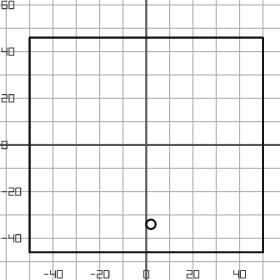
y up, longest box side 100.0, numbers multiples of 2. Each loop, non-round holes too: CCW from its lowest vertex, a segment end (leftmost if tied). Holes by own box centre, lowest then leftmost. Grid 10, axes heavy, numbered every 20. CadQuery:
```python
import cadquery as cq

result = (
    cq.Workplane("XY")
    .moveTo(-50.0, -46.0)
    .lineTo(50.0, -46.0)
    .lineTo(50.0, 46.0)
    .lineTo(-50.0, 46.0)
    .close()
    .moveTo(2.0, -34.0)
    .circle(2.0)
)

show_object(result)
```